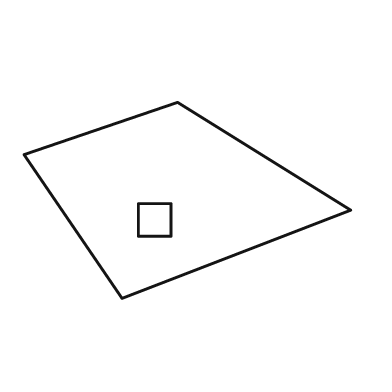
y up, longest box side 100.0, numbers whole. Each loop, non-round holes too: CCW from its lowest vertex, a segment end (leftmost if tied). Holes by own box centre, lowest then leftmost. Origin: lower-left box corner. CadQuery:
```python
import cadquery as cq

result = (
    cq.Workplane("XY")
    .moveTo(30.0, 0.0)
    .lineTo(100.0, 27.0)
    .lineTo(47.0, 60.0)
    .lineTo(0.0, 44.0)
    .close()
    .moveTo(35.0, 19.0)
    .lineTo(45.0, 19.0)
    .lineTo(45.0, 29.0)
    .lineTo(35.0, 29.0)
    .close()
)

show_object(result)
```